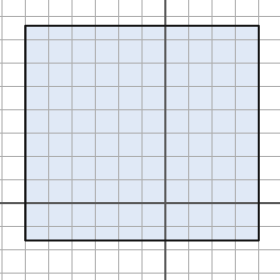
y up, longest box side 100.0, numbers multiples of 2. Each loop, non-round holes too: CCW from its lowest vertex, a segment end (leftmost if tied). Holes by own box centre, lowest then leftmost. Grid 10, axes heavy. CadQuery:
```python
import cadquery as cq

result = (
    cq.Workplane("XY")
    .moveTo(-60.0, -16.0)
    .lineTo(40.0, -16.0)
    .lineTo(40.0, 76.0)
    .lineTo(-60.0, 76.0)
    .close()
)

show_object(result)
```